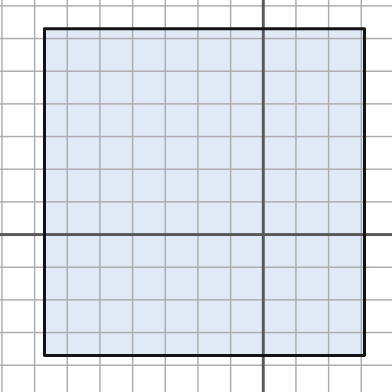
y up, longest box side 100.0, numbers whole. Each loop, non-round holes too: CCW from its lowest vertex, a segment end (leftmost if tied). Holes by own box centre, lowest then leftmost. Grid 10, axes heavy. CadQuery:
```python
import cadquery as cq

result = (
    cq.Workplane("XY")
    .moveTo(-67.0, -37.0)
    .lineTo(31.0, -37.0)
    .lineTo(31.0, 63.0)
    .lineTo(-67.0, 63.0)
    .close()
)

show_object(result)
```